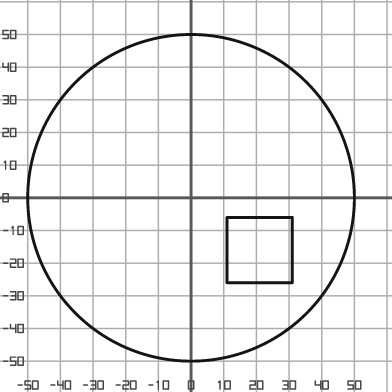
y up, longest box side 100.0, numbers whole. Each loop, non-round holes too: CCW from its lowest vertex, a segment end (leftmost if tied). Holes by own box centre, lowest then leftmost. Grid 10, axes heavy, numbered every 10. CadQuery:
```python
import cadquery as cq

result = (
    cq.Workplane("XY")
    .moveTo(0.0, 0.0)
    .circle(50.0)
    .moveTo(11.0, -26.0)
    .lineTo(31.0, -26.0)
    .lineTo(31.0, -6.0)
    .lineTo(11.0, -6.0)
    .close()
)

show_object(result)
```